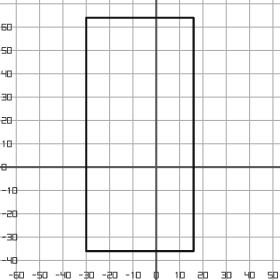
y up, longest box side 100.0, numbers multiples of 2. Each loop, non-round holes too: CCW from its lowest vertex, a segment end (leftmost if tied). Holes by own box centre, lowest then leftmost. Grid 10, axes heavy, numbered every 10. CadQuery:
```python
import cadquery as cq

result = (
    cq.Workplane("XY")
    .moveTo(-30.0, -36.0)
    .lineTo(16.0, -36.0)
    .lineTo(16.0, 64.0)
    .lineTo(-30.0, 64.0)
    .close()
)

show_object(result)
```